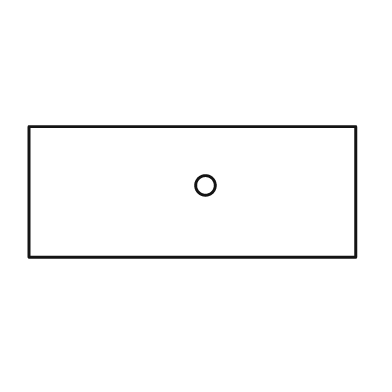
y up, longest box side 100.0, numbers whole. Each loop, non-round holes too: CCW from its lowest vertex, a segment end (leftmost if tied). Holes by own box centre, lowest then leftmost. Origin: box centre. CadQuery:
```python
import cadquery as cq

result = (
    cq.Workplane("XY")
    .moveTo(-50.0, -20.0)
    .lineTo(50.0, -20.0)
    .lineTo(50.0, 20.0)
    .lineTo(-50.0, 20.0)
    .close()
    .moveTo(4.0, 2.0)
    .circle(3.0)
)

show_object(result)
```